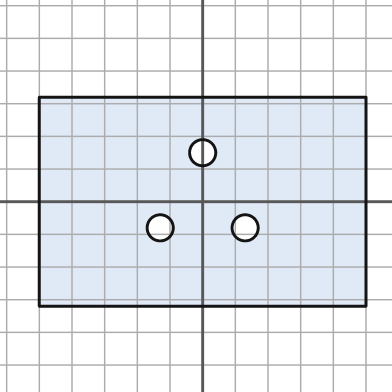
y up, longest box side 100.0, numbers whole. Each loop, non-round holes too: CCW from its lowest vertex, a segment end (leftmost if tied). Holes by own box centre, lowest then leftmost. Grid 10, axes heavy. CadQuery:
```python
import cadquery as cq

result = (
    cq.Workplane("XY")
    .moveTo(-50.0, -32.0)
    .lineTo(50.0, -32.0)
    .lineTo(50.0, 32.0)
    .lineTo(-50.0, 32.0)
    .close()
    .moveTo(-13.0, -8.0)
    .circle(4.0)
    .moveTo(13.0, -8.0)
    .circle(4.0)
    .moveTo(0.0, 15.0)
    .circle(4.0)
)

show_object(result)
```